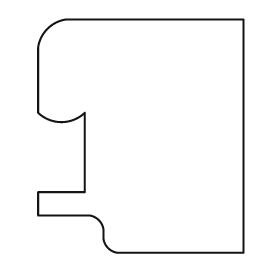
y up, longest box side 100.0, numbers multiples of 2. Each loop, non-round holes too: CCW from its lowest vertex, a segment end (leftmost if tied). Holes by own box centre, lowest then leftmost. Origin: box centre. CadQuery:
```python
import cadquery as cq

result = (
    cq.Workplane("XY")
    .moveTo(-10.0, -50.0)
    .lineTo(44.0, -50.0)
    .lineTo(44.0, 50.0)
    .lineTo(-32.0, 50.0)
    .threePointArc((-40.0, 46.0), (-44.0, 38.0))
    .lineTo(-44.0, 10.0)
    .threePointArc((-34.0, 6.0), (-24.0, 10.0))
    .lineTo(-24.0, -24.0)
    .lineTo(-44.0, -24.0)
    .lineTo(-44.0, -34.0)
    .lineTo(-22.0, -34.0)
    .threePointArc((-18.0, -36.0), (-16.0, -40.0))
    .lineTo(-16.0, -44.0)
    .threePointArc((-14.0, -48.0), (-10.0, -50.0))
    .close()
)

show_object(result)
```